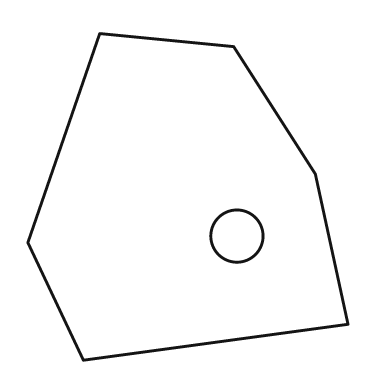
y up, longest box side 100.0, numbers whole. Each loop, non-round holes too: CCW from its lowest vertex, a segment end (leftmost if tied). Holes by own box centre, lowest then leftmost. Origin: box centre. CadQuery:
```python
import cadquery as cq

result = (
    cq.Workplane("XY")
    .moveTo(-32.0, -50.0)
    .lineTo(49.0, -39.0)
    .lineTo(39.0, 7.0)
    .lineTo(14.0, 46.0)
    .lineTo(-27.0, 50.0)
    .lineTo(-49.0, -14.0)
    .close()
    .moveTo(15.0, -12.0)
    .circle(8.0)
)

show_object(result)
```